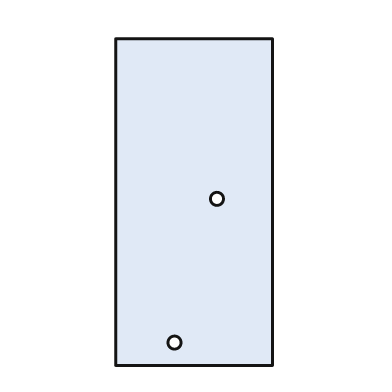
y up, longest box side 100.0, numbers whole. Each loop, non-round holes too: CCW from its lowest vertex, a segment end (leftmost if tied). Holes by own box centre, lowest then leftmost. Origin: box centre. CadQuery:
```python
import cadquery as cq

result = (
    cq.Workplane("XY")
    .moveTo(-24.0, -50.0)
    .lineTo(24.0, -50.0)
    .lineTo(24.0, 50.0)
    .lineTo(-24.0, 50.0)
    .close()
    .moveTo(-6.0, -43.0)
    .circle(2.0)
    .moveTo(7.0, 1.0)
    .circle(2.0)
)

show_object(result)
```